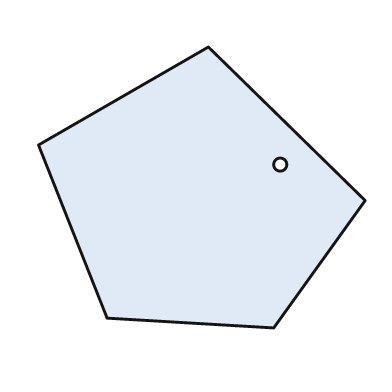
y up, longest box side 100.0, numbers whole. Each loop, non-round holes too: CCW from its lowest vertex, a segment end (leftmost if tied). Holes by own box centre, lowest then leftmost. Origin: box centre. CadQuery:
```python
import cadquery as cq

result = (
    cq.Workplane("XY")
    .moveTo(22.0, -43.0)
    .lineTo(50.0, -4.0)
    .lineTo(2.0, 43.0)
    .lineTo(-50.0, 13.0)
    .lineTo(-29.0, -40.0)
    .close()
    .moveTo(24.0, 7.0)
    .circle(2.0)
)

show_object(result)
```